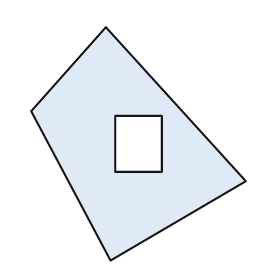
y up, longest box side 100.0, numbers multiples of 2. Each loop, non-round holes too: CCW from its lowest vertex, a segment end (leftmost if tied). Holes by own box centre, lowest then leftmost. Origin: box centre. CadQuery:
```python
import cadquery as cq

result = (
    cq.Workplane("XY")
    .moveTo(-12.0, -50.0)
    .lineTo(46.0, -16.0)
    .lineTo(-14.0, 50.0)
    .lineTo(-46.0, 14.0)
    .close()
    .moveTo(-10.0, -12.0)
    .lineTo(10.0, -12.0)
    .lineTo(10.0, 12.0)
    .lineTo(-10.0, 12.0)
    .close()
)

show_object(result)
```